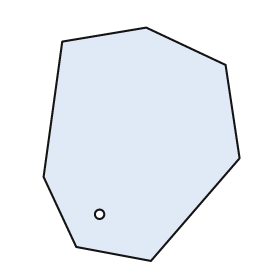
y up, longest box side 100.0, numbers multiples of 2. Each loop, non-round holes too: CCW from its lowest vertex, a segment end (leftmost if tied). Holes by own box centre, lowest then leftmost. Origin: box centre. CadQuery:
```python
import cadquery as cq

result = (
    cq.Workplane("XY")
    .moveTo(4.0, -50.0)
    .lineTo(42.0, -6.0)
    .lineTo(36.0, 34.0)
    .lineTo(2.0, 50.0)
    .lineTo(-34.0, 44.0)
    .lineTo(-42.0, -14.0)
    .lineTo(-28.0, -44.0)
    .close()
    .moveTo(-18.0, -30.0)
    .circle(2.0)
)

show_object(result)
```